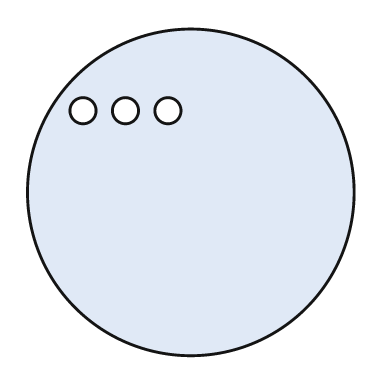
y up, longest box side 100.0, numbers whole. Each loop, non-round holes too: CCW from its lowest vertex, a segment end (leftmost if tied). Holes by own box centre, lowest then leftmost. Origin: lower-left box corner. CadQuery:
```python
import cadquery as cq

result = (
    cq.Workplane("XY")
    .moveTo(50.0, 50.0)
    .circle(50.0)
    .moveTo(17.0, 75.0)
    .circle(4.0)
    .moveTo(30.0, 75.0)
    .circle(4.0)
    .moveTo(43.0, 75.0)
    .circle(4.0)
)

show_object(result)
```